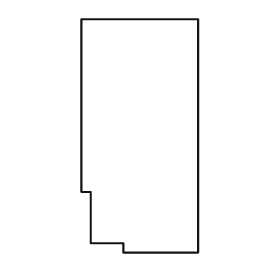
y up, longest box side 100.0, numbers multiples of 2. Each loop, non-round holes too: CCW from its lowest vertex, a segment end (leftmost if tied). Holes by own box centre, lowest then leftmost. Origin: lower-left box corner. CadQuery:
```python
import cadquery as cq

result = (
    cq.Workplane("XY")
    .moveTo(18.0, 0.0)
    .lineTo(50.0, 0.0)
    .lineTo(50.0, 100.0)
    .lineTo(0.0, 100.0)
    .lineTo(0.0, 26.0)
    .lineTo(4.0, 26.0)
    .lineTo(4.0, 4.0)
    .lineTo(18.0, 4.0)
    .close()
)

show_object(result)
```